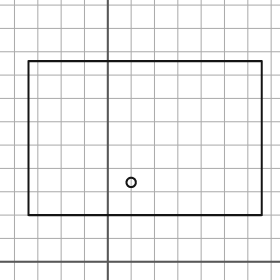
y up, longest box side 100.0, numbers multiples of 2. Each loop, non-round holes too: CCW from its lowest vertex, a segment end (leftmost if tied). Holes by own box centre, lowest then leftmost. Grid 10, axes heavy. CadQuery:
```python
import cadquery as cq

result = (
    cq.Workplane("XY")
    .moveTo(-34.0, 20.0)
    .lineTo(66.0, 20.0)
    .lineTo(66.0, 86.0)
    .lineTo(-34.0, 86.0)
    .close()
    .moveTo(10.0, 34.0)
    .circle(2.0)
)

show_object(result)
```